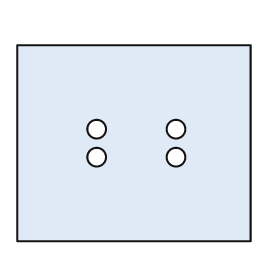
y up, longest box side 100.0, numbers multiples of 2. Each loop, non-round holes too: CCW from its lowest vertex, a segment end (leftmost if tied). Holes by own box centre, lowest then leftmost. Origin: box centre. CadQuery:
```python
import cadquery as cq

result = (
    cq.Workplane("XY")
    .moveTo(-50.0, -42.0)
    .lineTo(50.0, -42.0)
    .lineTo(50.0, 42.0)
    .lineTo(-50.0, 42.0)
    .close()
    .moveTo(-16.0, -6.0)
    .circle(4.0)
    .moveTo(18.0, -6.0)
    .circle(4.0)
    .moveTo(-16.0, 6.0)
    .circle(4.0)
    .moveTo(18.0, 6.0)
    .circle(4.0)
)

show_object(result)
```